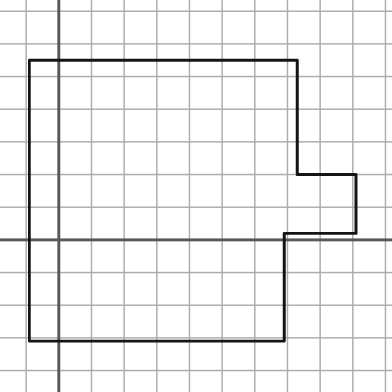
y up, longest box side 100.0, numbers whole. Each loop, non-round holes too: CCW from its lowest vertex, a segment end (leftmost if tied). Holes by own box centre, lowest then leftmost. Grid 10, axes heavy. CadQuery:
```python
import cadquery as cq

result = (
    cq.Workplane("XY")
    .moveTo(-9.0, -31.0)
    .lineTo(69.0, -31.0)
    .lineTo(69.0, 2.0)
    .lineTo(91.0, 2.0)
    .lineTo(91.0, 20.0)
    .lineTo(73.0, 20.0)
    .lineTo(73.0, 55.0)
    .lineTo(-9.0, 55.0)
    .close()
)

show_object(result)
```